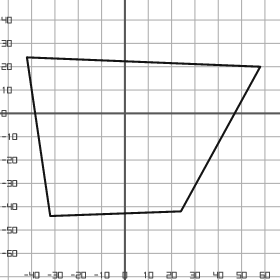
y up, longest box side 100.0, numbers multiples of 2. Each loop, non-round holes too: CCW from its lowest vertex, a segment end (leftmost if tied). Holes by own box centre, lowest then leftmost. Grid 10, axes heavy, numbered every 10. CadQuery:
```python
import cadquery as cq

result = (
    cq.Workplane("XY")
    .moveTo(-32.0, -44.0)
    .lineTo(24.0, -42.0)
    .lineTo(58.0, 20.0)
    .lineTo(-42.0, 24.0)
    .close()
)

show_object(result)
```